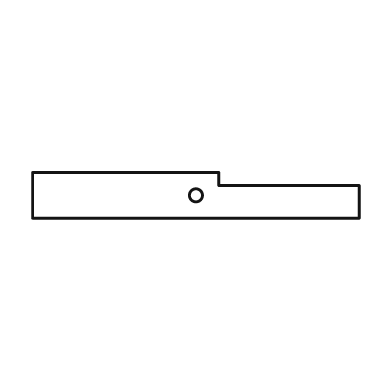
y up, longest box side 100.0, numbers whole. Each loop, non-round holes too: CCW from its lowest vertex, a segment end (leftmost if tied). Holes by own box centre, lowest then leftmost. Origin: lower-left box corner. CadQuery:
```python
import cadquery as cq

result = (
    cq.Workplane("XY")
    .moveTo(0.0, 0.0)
    .lineTo(100.0, 0.0)
    .lineTo(100.0, 10.0)
    .lineTo(57.0, 10.0)
    .lineTo(57.0, 14.0)
    .lineTo(0.0, 14.0)
    .close()
    .moveTo(50.0, 7.0)
    .circle(2.0)
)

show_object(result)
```